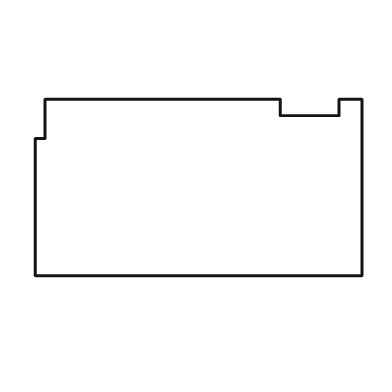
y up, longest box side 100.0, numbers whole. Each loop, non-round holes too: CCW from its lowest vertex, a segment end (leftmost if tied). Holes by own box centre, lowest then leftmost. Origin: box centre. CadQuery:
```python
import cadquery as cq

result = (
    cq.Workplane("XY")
    .moveTo(-50.0, -27.0)
    .lineTo(50.0, -27.0)
    .lineTo(50.0, 27.0)
    .lineTo(43.0, 27.0)
    .lineTo(43.0, 22.0)
    .lineTo(25.0, 22.0)
    .lineTo(25.0, 27.0)
    .lineTo(-47.0, 27.0)
    .lineTo(-47.0, 15.0)
    .lineTo(-50.0, 15.0)
    .close()
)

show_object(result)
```